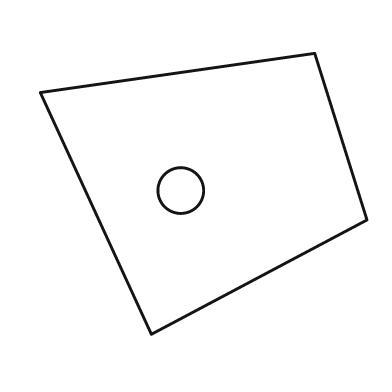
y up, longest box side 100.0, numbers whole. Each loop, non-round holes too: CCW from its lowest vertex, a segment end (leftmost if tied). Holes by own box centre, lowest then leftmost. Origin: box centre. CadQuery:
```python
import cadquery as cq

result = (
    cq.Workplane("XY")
    .moveTo(-16.0, -43.0)
    .lineTo(50.0, -8.0)
    .lineTo(34.0, 43.0)
    .lineTo(-50.0, 31.0)
    .close()
    .moveTo(-7.0, 1.0)
    .circle(7.0)
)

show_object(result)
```